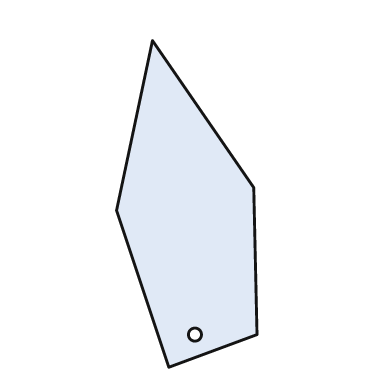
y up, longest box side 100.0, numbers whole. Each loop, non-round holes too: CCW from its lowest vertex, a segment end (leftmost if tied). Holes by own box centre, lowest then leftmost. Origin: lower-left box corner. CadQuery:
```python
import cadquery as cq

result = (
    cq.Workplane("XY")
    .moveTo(16.0, 0.0)
    .lineTo(43.0, 10.0)
    .lineTo(42.0, 55.0)
    .lineTo(11.0, 100.0)
    .lineTo(0.0, 48.0)
    .close()
    .moveTo(24.0, 10.0)
    .circle(2.0)
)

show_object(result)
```